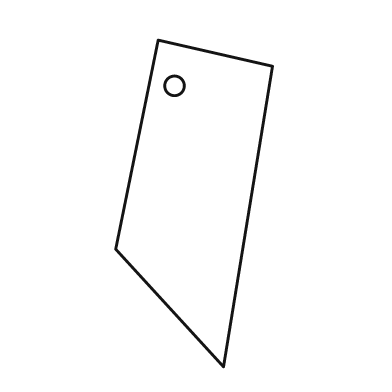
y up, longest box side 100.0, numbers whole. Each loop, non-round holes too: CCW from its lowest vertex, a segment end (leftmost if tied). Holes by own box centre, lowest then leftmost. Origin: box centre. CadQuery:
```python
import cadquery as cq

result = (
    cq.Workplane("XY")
    .moveTo(9.0, -50.0)
    .lineTo(24.0, 42.0)
    .lineTo(-11.0, 50.0)
    .lineTo(-24.0, -14.0)
    .close()
    .moveTo(-6.0, 36.0)
    .circle(3.0)
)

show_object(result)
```